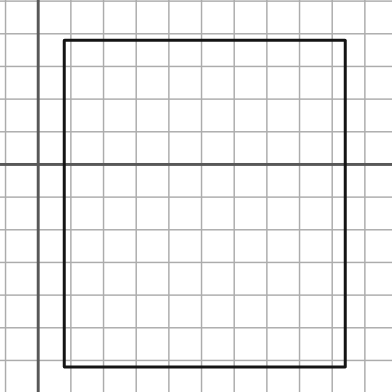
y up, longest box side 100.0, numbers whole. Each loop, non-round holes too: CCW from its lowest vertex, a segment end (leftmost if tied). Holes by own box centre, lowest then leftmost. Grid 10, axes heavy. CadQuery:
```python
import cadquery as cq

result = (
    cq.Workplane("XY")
    .moveTo(8.0, -62.0)
    .lineTo(94.0, -62.0)
    .lineTo(94.0, 38.0)
    .lineTo(8.0, 38.0)
    .close()
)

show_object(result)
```